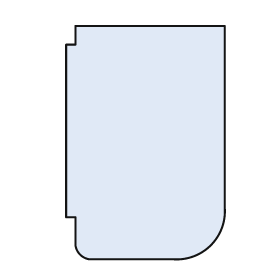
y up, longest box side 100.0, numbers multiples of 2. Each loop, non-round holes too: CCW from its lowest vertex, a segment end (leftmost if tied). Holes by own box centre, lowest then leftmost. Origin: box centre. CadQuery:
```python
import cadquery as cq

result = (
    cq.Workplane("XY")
    .moveTo(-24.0, -50.0)
    .lineTo(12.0, -50.0)
    .threePointArc((28.0, -44.0), (34.0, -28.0))
    .lineTo(34.0, 50.0)
    .lineTo(-30.0, 50.0)
    .lineTo(-30.0, 42.0)
    .lineTo(-34.0, 42.0)
    .lineTo(-34.0, -32.0)
    .lineTo(-30.0, -32.0)
    .lineTo(-30.0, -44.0)
    .threePointArc((-28.0, -48.0), (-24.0, -50.0))
    .close()
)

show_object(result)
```